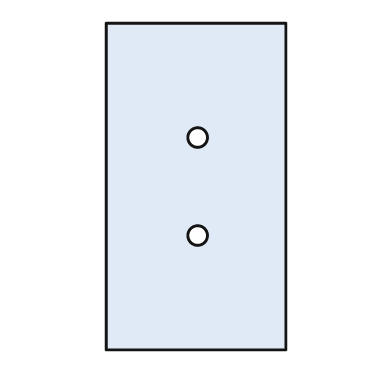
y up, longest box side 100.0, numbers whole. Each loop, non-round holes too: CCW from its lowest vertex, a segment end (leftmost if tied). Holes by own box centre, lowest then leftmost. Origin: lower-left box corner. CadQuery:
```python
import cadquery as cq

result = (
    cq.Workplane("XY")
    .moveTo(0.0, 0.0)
    .lineTo(55.0, 0.0)
    .lineTo(55.0, 100.0)
    .lineTo(0.0, 100.0)
    .close()
    .moveTo(28.0, 35.0)
    .circle(3.0)
    .moveTo(28.0, 65.0)
    .circle(3.0)
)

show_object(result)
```